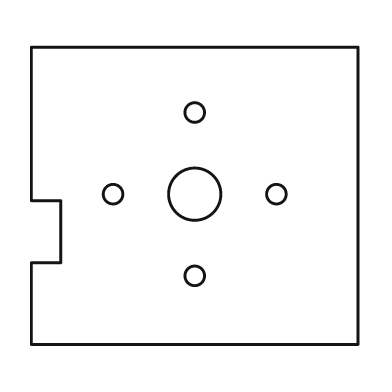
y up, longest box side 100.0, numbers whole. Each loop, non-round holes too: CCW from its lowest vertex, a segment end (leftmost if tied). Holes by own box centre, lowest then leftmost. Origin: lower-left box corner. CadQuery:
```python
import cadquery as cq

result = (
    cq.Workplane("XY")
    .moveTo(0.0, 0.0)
    .lineTo(100.0, 0.0)
    .lineTo(100.0, 91.0)
    .lineTo(0.0, 91.0)
    .lineTo(0.0, 44.0)
    .lineTo(9.0, 44.0)
    .lineTo(9.0, 25.0)
    .lineTo(0.0, 25.0)
    .close()
    .moveTo(50.0, 21.0)
    .circle(3.0)
    .moveTo(25.0, 46.0)
    .circle(3.0)
    .moveTo(50.0, 46.0)
    .circle(8.0)
    .moveTo(75.0, 46.0)
    .circle(3.0)
    .moveTo(50.0, 71.0)
    .circle(3.0)
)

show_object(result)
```